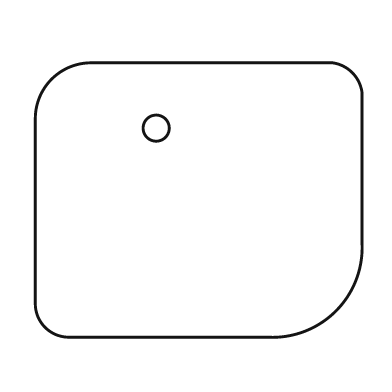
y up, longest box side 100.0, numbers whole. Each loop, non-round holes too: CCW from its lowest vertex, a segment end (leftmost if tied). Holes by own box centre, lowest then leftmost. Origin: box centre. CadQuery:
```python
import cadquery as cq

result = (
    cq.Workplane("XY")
    .moveTo(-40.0, -42.0)
    .lineTo(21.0, -42.0)
    .threePointArc((42.0, -34.0), (50.0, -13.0))
    .lineTo(50.0, 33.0)
    .threePointArc((47.0, 39.0), (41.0, 42.0))
    .lineTo(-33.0, 42.0)
    .threePointArc((-45.0, 37.0), (-50.0, 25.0))
    .lineTo(-50.0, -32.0)
    .threePointArc((-47.0, -39.0), (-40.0, -42.0))
    .close()
    .moveTo(-13.0, 22.0)
    .circle(4.0)
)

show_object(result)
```